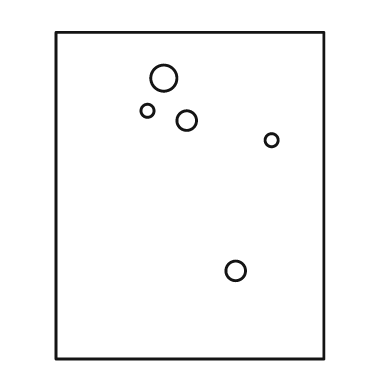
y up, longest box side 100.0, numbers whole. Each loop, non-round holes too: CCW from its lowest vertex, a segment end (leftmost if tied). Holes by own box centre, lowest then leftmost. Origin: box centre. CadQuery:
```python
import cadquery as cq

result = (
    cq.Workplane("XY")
    .moveTo(-41.0, -50.0)
    .lineTo(41.0, -50.0)
    .lineTo(41.0, 50.0)
    .lineTo(-41.0, 50.0)
    .close()
    .moveTo(14.0, -23.0)
    .circle(3.0)
    .moveTo(25.0, 17.0)
    .circle(2.0)
    .moveTo(-1.0, 23.0)
    .circle(3.0)
    .moveTo(-13.0, 26.0)
    .circle(2.0)
    .moveTo(-8.0, 36.0)
    .circle(4.0)
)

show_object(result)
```